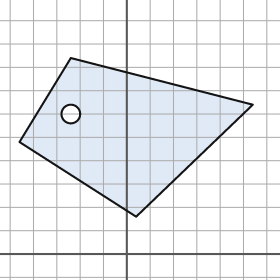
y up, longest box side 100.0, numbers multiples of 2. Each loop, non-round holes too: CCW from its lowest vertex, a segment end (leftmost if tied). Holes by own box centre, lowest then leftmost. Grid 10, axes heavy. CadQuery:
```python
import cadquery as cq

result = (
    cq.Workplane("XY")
    .moveTo(4.0, 16.0)
    .lineTo(54.0, 64.0)
    .lineTo(-24.0, 84.0)
    .lineTo(-46.0, 48.0)
    .close()
    .moveTo(-24.0, 60.0)
    .circle(4.0)
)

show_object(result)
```